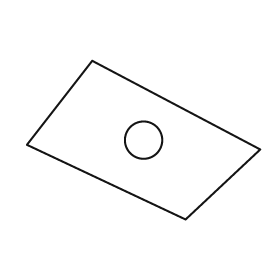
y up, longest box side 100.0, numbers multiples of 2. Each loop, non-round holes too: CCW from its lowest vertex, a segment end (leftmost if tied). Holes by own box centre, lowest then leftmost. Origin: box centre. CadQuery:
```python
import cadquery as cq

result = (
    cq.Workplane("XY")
    .moveTo(18.0, -34.0)
    .lineTo(50.0, -4.0)
    .lineTo(-22.0, 34.0)
    .lineTo(-50.0, -2.0)
    .close()
    .moveTo(0.0, 0.0)
    .circle(8.0)
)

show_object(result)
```